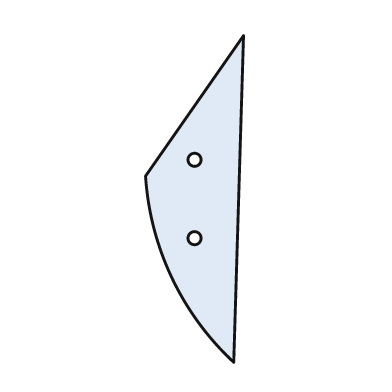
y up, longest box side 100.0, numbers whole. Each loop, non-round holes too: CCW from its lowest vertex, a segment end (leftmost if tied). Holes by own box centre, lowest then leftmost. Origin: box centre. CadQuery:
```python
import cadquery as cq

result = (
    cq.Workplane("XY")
    .moveTo(12.0, -50.0)
    .lineTo(15.0, 50.0)
    .lineTo(-15.0, 7.0)
    .threePointArc((-7.0, -24.0), (12.0, -50.0))
    .close()
    .moveTo(0.0, -12.0)
    .circle(2.0)
    .moveTo(0.0, 12.0)
    .circle(2.0)
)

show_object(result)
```